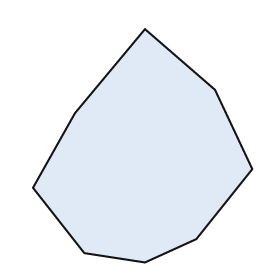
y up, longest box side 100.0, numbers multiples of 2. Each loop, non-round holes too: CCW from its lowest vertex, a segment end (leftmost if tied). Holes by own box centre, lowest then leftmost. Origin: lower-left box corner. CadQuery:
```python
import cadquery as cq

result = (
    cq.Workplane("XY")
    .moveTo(48.0, 0.0)
    .lineTo(70.0, 10.0)
    .lineTo(94.0, 40.0)
    .lineTo(78.0, 74.0)
    .lineTo(48.0, 100.0)
    .lineTo(18.0, 64.0)
    .lineTo(0.0, 32.0)
    .lineTo(22.0, 4.0)
    .close()
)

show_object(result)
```